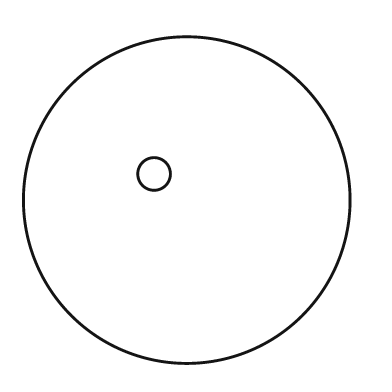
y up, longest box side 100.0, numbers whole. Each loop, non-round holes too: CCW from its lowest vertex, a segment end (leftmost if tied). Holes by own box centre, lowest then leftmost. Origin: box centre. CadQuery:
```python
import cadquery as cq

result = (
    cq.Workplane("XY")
    .moveTo(0.0, 0.0)
    .circle(50.0)
    .moveTo(-10.0, 8.0)
    .circle(5.0)
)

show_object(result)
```